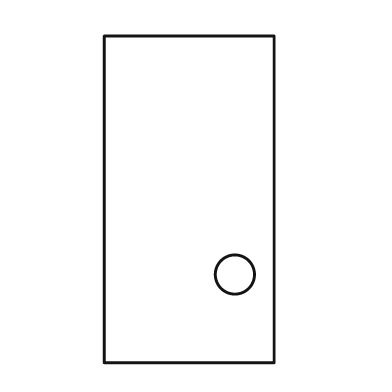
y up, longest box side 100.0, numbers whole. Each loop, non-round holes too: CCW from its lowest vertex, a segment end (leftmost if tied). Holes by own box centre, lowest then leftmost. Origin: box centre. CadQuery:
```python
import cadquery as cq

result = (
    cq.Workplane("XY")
    .moveTo(-26.0, -50.0)
    .lineTo(26.0, -50.0)
    .lineTo(26.0, 50.0)
    .lineTo(-26.0, 50.0)
    .close()
    .moveTo(14.0, -23.0)
    .circle(6.0)
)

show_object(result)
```